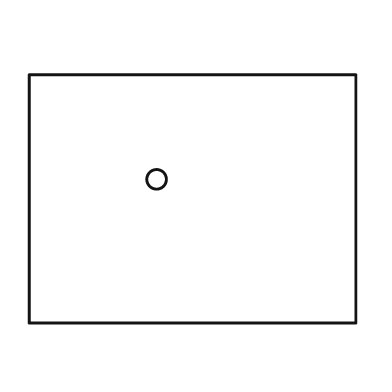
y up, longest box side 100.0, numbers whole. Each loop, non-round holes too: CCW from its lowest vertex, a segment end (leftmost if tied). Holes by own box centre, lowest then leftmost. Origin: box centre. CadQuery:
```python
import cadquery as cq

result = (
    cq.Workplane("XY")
    .moveTo(-50.0, -38.0)
    .lineTo(50.0, -38.0)
    .lineTo(50.0, 38.0)
    .lineTo(-50.0, 38.0)
    .close()
    .moveTo(-11.0, 6.0)
    .circle(3.0)
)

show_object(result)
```